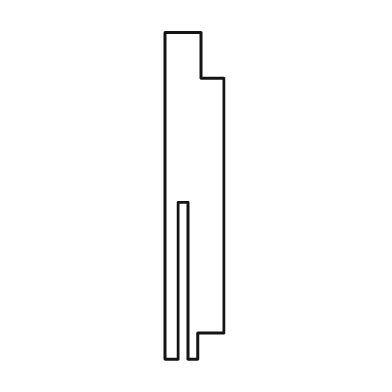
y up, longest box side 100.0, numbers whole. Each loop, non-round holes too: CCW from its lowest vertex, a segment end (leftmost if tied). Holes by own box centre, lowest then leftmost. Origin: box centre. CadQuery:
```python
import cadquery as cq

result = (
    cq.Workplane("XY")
    .moveTo(-9.0, -50.0)
    .lineTo(-5.0, -50.0)
    .lineTo(-5.0, -2.0)
    .lineTo(-2.0, -2.0)
    .lineTo(-2.0, -50.0)
    .lineTo(1.0, -50.0)
    .lineTo(1.0, -42.0)
    .lineTo(9.0, -42.0)
    .lineTo(9.0, 36.0)
    .lineTo(2.0, 36.0)
    .lineTo(2.0, 50.0)
    .lineTo(-9.0, 50.0)
    .close()
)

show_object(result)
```